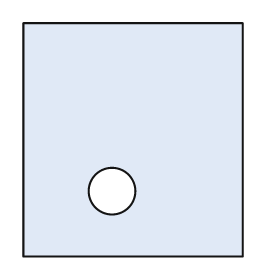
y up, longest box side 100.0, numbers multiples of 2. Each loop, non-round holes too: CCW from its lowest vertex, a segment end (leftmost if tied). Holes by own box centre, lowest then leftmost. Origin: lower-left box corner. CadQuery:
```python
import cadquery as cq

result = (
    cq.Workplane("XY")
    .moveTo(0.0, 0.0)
    .lineTo(94.0, 0.0)
    .lineTo(94.0, 100.0)
    .lineTo(0.0, 100.0)
    .close()
    .moveTo(38.0, 28.0)
    .circle(10.0)
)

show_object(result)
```